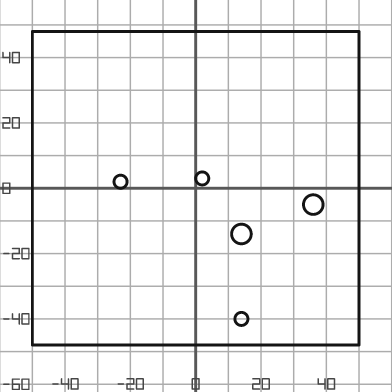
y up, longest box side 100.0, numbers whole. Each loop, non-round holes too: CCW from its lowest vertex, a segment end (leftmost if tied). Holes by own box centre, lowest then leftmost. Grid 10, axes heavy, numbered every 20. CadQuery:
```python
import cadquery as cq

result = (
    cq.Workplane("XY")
    .moveTo(-50.0, -48.0)
    .lineTo(50.0, -48.0)
    .lineTo(50.0, 48.0)
    .lineTo(-50.0, 48.0)
    .close()
    .moveTo(14.0, -40.0)
    .circle(2.0)
    .moveTo(14.0, -14.0)
    .circle(3.0)
    .moveTo(36.0, -5.0)
    .circle(3.0)
    .moveTo(-23.0, 2.0)
    .circle(2.0)
    .moveTo(2.0, 3.0)
    .circle(2.0)
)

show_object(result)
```